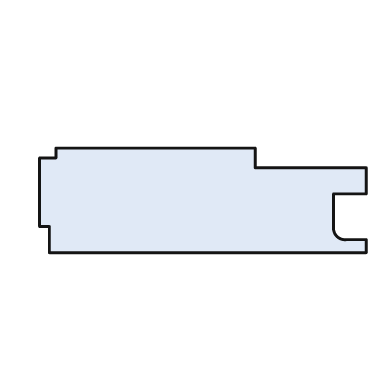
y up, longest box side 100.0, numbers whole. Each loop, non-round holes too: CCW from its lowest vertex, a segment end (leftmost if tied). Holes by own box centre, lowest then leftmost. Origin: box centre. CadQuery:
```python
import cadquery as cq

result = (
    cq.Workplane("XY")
    .moveTo(-47.0, -16.0)
    .lineTo(50.0, -16.0)
    .lineTo(50.0, -12.0)
    .lineTo(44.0, -12.0)
    .threePointArc((41.0, -11.0), (40.0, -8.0))
    .lineTo(40.0, 2.0)
    .lineTo(50.0, 2.0)
    .lineTo(50.0, 10.0)
    .lineTo(16.0, 10.0)
    .lineTo(16.0, 16.0)
    .lineTo(-45.0, 16.0)
    .lineTo(-45.0, 13.0)
    .lineTo(-50.0, 13.0)
    .lineTo(-50.0, -8.0)
    .lineTo(-47.0, -8.0)
    .close()
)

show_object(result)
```